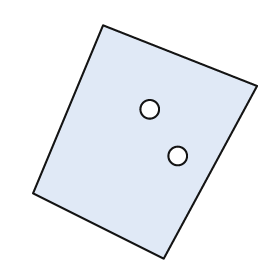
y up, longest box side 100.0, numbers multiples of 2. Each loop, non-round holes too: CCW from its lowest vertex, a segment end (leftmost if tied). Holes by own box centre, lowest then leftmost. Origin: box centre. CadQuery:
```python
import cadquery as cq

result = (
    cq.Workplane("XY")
    .moveTo(8.0, -50.0)
    .lineTo(48.0, 24.0)
    .lineTo(-18.0, 50.0)
    .lineTo(-48.0, -22.0)
    .close()
    .moveTo(14.0, -6.0)
    .circle(4.0)
    .moveTo(2.0, 14.0)
    .circle(4.0)
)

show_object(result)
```